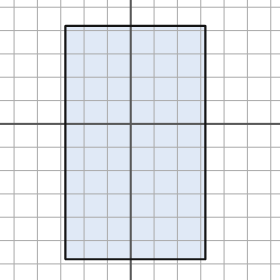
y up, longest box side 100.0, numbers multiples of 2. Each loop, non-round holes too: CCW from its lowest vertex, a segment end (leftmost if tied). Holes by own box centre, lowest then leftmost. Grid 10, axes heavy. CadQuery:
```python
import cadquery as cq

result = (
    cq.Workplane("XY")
    .moveTo(-28.0, -58.0)
    .lineTo(32.0, -58.0)
    .lineTo(32.0, 42.0)
    .lineTo(-28.0, 42.0)
    .close()
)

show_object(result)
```